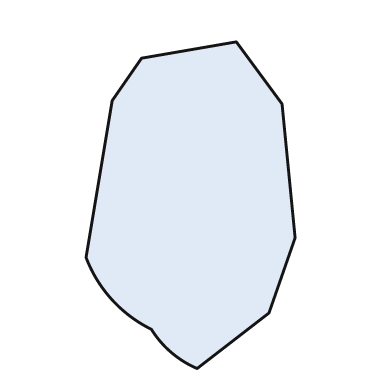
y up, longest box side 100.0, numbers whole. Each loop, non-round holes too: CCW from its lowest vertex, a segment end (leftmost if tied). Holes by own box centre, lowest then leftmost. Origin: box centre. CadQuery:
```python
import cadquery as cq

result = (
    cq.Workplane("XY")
    .moveTo(2.0, -50.0)
    .lineTo(24.0, -33.0)
    .lineTo(32.0, -10.0)
    .lineTo(28.0, 31.0)
    .lineTo(14.0, 50.0)
    .lineTo(-15.0, 45.0)
    .lineTo(-24.0, 32.0)
    .lineTo(-32.0, -16.0)
    .threePointArc((-24.0, -29.0), (-12.0, -38.0))
    .threePointArc((-6.0, -45.0), (2.0, -50.0))
    .close()
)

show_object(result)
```